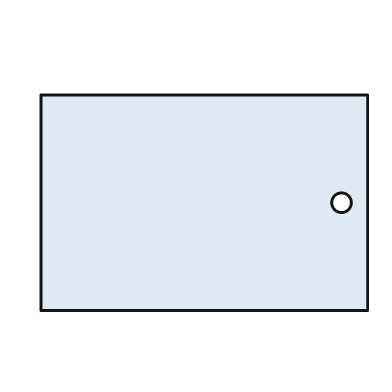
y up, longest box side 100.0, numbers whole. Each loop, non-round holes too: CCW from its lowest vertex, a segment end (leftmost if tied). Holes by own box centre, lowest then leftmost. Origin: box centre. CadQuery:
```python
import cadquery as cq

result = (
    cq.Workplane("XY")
    .moveTo(-50.0, -33.0)
    .lineTo(50.0, -33.0)
    .lineTo(50.0, 33.0)
    .lineTo(-50.0, 33.0)
    .close()
    .moveTo(42.0, 0.0)
    .circle(3.0)
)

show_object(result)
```